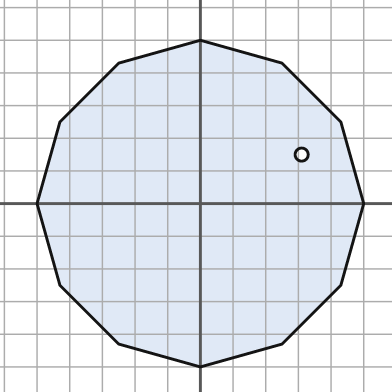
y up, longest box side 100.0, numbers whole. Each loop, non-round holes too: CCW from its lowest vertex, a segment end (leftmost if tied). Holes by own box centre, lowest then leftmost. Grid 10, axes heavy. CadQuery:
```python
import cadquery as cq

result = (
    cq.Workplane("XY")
    .moveTo(0.0, -50.0)
    .lineTo(25.0, -43.0)
    .lineTo(43.0, -25.0)
    .lineTo(50.0, 0.0)
    .lineTo(43.0, 25.0)
    .lineTo(25.0, 43.0)
    .lineTo(0.0, 50.0)
    .lineTo(-25.0, 43.0)
    .lineTo(-43.0, 25.0)
    .lineTo(-50.0, 0.0)
    .lineTo(-43.0, -25.0)
    .lineTo(-25.0, -43.0)
    .close()
    .moveTo(31.0, 15.0)
    .circle(2.0)
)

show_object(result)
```